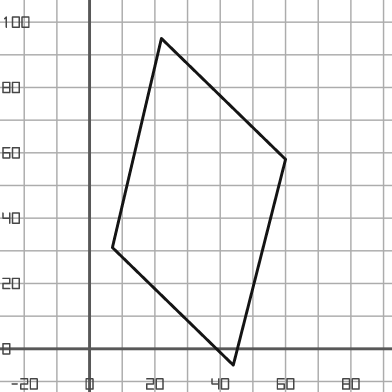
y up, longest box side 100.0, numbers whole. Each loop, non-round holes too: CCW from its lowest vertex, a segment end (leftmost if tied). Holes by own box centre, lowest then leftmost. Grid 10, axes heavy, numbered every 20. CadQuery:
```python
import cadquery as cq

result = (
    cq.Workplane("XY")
    .moveTo(44.0, -5.0)
    .lineTo(60.0, 58.0)
    .lineTo(22.0, 95.0)
    .lineTo(7.0, 31.0)
    .close()
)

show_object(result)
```